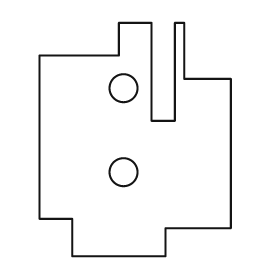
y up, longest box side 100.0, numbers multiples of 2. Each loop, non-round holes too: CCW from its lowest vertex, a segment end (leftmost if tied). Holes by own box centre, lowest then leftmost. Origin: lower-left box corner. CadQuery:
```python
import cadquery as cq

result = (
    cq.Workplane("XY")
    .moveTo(14.0, 0.0)
    .lineTo(54.0, 0.0)
    .lineTo(54.0, 12.0)
    .lineTo(82.0, 12.0)
    .lineTo(82.0, 76.0)
    .lineTo(62.0, 76.0)
    .lineTo(62.0, 100.0)
    .lineTo(58.0, 100.0)
    .lineTo(58.0, 58.0)
    .lineTo(48.0, 58.0)
    .lineTo(48.0, 100.0)
    .lineTo(34.0, 100.0)
    .lineTo(34.0, 86.0)
    .lineTo(0.0, 86.0)
    .lineTo(0.0, 16.0)
    .lineTo(14.0, 16.0)
    .close()
    .moveTo(36.0, 36.0)
    .circle(6.0)
    .moveTo(36.0, 72.0)
    .circle(6.0)
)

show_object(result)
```